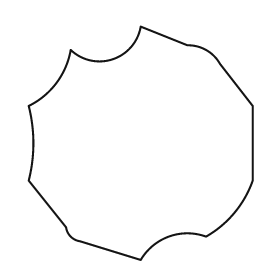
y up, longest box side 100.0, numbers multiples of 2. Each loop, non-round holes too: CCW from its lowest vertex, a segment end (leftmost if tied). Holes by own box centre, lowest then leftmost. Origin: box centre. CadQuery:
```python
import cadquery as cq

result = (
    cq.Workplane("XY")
    .moveTo(0.0, -50.0)
    .threePointArc((12.0, -40.0), (28.0, -40.0))
    .threePointArc((40.0, -30.0), (48.0, -16.0))
    .lineTo(48.0, 16.0)
    .lineTo(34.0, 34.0)
    .threePointArc((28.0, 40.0), (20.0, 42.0))
    .lineTo(0.0, 50.0)
    .threePointArc((-12.0, 36.0), (-30.0, 40.0))
    .threePointArc((-36.0, 26.0), (-48.0, 16.0))
    .threePointArc((-46.0, 0.0), (-48.0, -16.0))
    .lineTo(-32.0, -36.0)
    .threePointArc((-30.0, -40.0), (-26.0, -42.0))
    .close()
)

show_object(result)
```